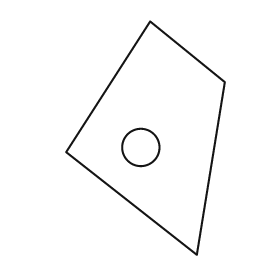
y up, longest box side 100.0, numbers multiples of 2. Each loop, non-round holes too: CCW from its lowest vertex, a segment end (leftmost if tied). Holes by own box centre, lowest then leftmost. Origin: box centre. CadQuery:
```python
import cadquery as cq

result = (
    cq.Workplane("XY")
    .moveTo(22.0, -50.0)
    .lineTo(34.0, 24.0)
    .lineTo(2.0, 50.0)
    .lineTo(-34.0, -6.0)
    .close()
    .moveTo(-2.0, -4.0)
    .circle(8.0)
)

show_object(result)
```